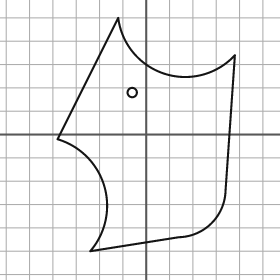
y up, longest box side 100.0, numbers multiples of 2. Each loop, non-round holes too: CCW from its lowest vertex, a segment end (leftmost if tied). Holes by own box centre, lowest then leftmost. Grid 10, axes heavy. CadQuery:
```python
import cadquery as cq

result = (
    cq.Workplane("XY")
    .moveTo(-24.0, -50.0)
    .lineTo(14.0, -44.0)
    .threePointArc((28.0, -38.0), (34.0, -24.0))
    .lineTo(38.0, 34.0)
    .threePointArc((8.0, 26.0), (-12.0, 50.0))
    .lineTo(-38.0, -2.0)
    .threePointArc((-18.0, -22.0), (-24.0, -50.0))
    .close()
    .moveTo(-6.0, 18.0)
    .circle(2.0)
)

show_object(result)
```